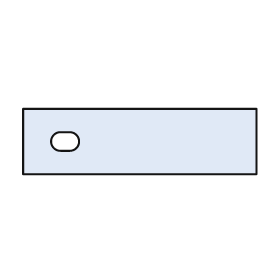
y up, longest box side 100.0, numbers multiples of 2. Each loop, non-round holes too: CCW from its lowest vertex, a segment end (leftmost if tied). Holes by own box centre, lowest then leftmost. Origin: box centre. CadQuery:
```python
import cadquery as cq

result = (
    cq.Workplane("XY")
    .moveTo(-50.0, -14.0)
    .lineTo(50.0, -14.0)
    .lineTo(50.0, 14.0)
    .lineTo(-50.0, 14.0)
    .close()
    .moveTo(-34.0, -4.0)
    .lineTo(-30.0, -4.0)
    .threePointArc((-26.0, 0.0), (-30.0, 4.0))
    .lineTo(-34.0, 4.0)
    .threePointArc((-38.0, 0.0), (-34.0, -4.0))
    .close()
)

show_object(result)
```